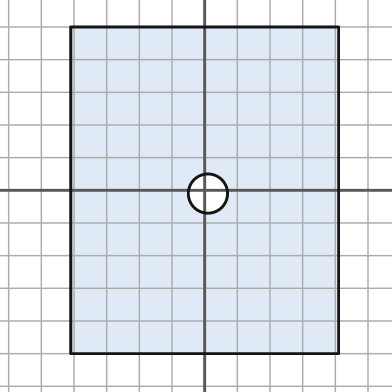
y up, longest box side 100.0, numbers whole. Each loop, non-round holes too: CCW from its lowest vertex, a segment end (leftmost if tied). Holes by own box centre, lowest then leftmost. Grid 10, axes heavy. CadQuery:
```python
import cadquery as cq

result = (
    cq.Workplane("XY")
    .moveTo(-41.0, -50.0)
    .lineTo(41.0, -50.0)
    .lineTo(41.0, 50.0)
    .lineTo(-41.0, 50.0)
    .close()
    .moveTo(1.0, -1.0)
    .circle(6.0)
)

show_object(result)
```